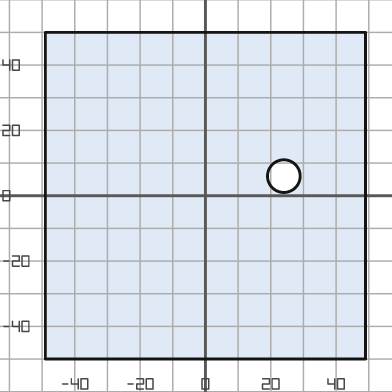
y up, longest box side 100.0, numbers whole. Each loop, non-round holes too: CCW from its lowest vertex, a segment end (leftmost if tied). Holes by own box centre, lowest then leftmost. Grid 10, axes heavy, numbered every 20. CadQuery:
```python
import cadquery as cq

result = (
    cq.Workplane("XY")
    .moveTo(-49.0, -50.0)
    .lineTo(49.0, -50.0)
    .lineTo(49.0, 50.0)
    .lineTo(-49.0, 50.0)
    .close()
    .moveTo(24.0, 6.0)
    .circle(5.0)
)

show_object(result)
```